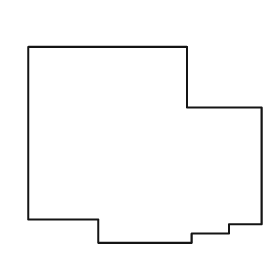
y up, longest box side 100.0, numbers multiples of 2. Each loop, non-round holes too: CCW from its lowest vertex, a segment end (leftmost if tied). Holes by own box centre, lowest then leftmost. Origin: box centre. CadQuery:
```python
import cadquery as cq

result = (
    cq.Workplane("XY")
    .moveTo(-20.0, -42.0)
    .lineTo(20.0, -42.0)
    .lineTo(20.0, -38.0)
    .lineTo(36.0, -38.0)
    .lineTo(36.0, -34.0)
    .lineTo(50.0, -34.0)
    .lineTo(50.0, 16.0)
    .lineTo(18.0, 16.0)
    .lineTo(18.0, 42.0)
    .lineTo(-50.0, 42.0)
    .lineTo(-50.0, -32.0)
    .lineTo(-20.0, -32.0)
    .close()
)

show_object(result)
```